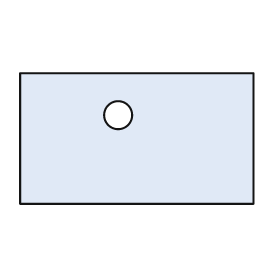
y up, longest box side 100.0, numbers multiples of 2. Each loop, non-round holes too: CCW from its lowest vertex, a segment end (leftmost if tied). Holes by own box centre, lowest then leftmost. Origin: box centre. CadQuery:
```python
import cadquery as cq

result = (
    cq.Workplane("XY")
    .moveTo(-50.0, -28.0)
    .lineTo(50.0, -28.0)
    .lineTo(50.0, 28.0)
    .lineTo(-50.0, 28.0)
    .close()
    .moveTo(-8.0, 10.0)
    .circle(6.0)
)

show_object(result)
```